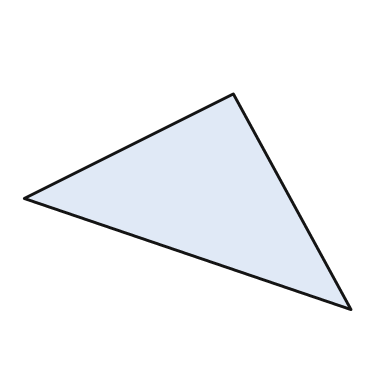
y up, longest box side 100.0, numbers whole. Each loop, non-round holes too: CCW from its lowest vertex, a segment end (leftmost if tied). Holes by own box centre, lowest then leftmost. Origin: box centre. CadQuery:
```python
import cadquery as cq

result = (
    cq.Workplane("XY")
    .moveTo(50.0, -33.0)
    .lineTo(14.0, 33.0)
    .lineTo(-50.0, 1.0)
    .close()
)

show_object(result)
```